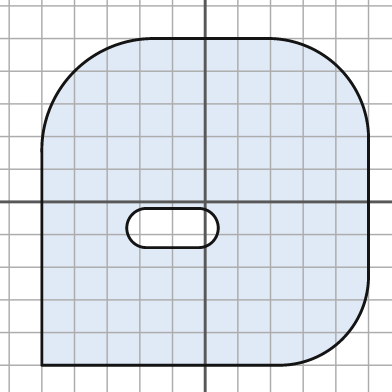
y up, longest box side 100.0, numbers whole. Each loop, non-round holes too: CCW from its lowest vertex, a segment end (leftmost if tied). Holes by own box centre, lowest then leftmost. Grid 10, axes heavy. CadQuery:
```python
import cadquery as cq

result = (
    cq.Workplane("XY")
    .moveTo(-50.0, -50.0)
    .lineTo(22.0, -50.0)
    .threePointArc((42.0, -42.0), (50.0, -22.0))
    .lineTo(50.0, 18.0)
    .threePointArc((41.0, 41.0), (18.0, 50.0))
    .lineTo(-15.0, 50.0)
    .threePointArc((-40.0, 40.0), (-50.0, 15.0))
    .close()
    .moveTo(-18.0, -14.0)
    .lineTo(-2.0, -14.0)
    .threePointArc((4.0, -8.0), (-2.0, -2.0))
    .lineTo(-18.0, -2.0)
    .threePointArc((-24.0, -8.0), (-18.0, -14.0))
    .close()
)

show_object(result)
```